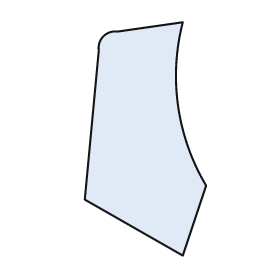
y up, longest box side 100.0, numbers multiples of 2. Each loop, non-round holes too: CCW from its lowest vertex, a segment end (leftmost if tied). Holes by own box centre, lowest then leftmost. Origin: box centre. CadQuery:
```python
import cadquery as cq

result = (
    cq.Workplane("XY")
    .moveTo(16.0, -50.0)
    .lineTo(26.0, -20.0)
    .threePointArc((14.0, 14.0), (16.0, 50.0))
    .lineTo(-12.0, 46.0)
    .threePointArc((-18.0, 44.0), (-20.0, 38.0))
    .lineTo(-26.0, -26.0)
    .close()
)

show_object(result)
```